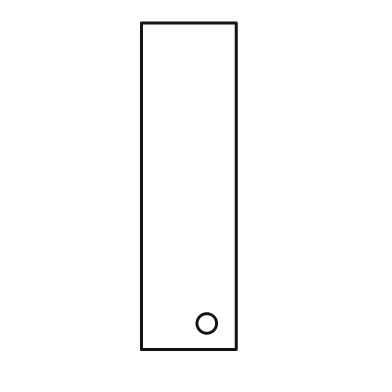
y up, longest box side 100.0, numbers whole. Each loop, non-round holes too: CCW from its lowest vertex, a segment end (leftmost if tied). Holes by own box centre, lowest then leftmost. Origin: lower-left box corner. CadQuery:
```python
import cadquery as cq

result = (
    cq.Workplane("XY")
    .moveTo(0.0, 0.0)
    .lineTo(29.0, 0.0)
    .lineTo(29.0, 100.0)
    .lineTo(0.0, 100.0)
    .close()
    .moveTo(20.0, 8.0)
    .circle(3.0)
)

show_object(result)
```